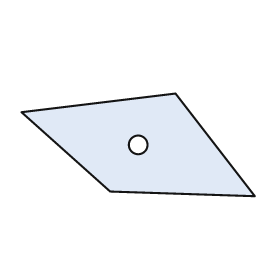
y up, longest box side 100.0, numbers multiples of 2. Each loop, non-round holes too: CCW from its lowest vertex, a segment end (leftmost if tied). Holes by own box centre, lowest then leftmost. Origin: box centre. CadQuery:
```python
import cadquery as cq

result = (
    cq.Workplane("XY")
    .moveTo(50.0, -22.0)
    .lineTo(16.0, 22.0)
    .lineTo(-50.0, 14.0)
    .lineTo(-12.0, -20.0)
    .close()
    .moveTo(0.0, 0.0)
    .circle(4.0)
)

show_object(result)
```